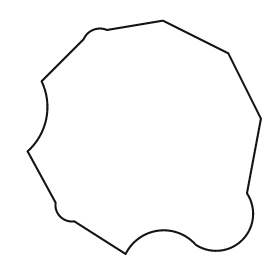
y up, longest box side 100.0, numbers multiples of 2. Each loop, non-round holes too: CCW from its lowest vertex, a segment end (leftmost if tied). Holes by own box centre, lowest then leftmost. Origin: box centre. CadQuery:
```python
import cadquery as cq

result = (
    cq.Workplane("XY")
    .moveTo(-8.0, -50.0)
    .threePointArc((6.0, -40.0), (22.0, -46.0))
    .threePointArc((42.0, -44.0), (44.0, -24.0))
    .lineTo(50.0, 8.0)
    .lineTo(36.0, 36.0)
    .lineTo(8.0, 50.0)
    .lineTo(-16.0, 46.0)
    .threePointArc((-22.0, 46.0), (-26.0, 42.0))
    .lineTo(-44.0, 24.0)
    .threePointArc((-42.0, 8.0), (-50.0, -6.0))
    .lineTo(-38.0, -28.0)
    .threePointArc((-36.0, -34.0), (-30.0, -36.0))
    .close()
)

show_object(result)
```